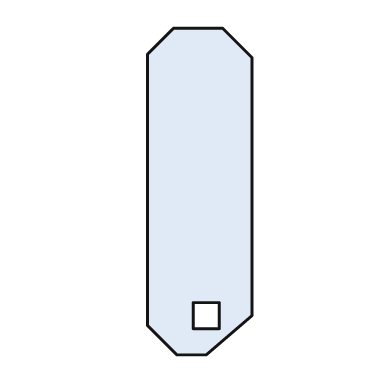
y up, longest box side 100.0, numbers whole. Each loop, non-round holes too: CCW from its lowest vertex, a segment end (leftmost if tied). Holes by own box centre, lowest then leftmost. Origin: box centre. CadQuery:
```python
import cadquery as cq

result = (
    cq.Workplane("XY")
    .moveTo(-7.0, -50.0)
    .lineTo(2.0, -50.0)
    .lineTo(16.0, -38.0)
    .lineTo(16.0, 41.0)
    .lineTo(7.0, 50.0)
    .lineTo(-8.0, 50.0)
    .lineTo(-16.0, 42.0)
    .lineTo(-16.0, -41.0)
    .close()
    .moveTo(-2.0, -42.0)
    .lineTo(6.0, -42.0)
    .lineTo(6.0, -34.0)
    .lineTo(-2.0, -34.0)
    .close()
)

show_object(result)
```